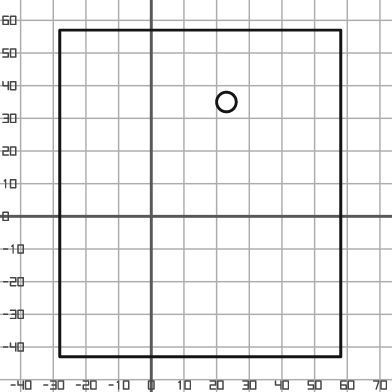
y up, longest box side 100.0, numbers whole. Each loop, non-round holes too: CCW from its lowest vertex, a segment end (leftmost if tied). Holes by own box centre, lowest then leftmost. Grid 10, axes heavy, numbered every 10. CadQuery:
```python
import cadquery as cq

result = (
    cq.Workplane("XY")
    .moveTo(-28.0, -43.0)
    .lineTo(58.0, -43.0)
    .lineTo(58.0, 57.0)
    .lineTo(-28.0, 57.0)
    .close()
    .moveTo(23.0, 35.0)
    .circle(3.0)
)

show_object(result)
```